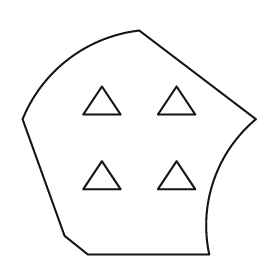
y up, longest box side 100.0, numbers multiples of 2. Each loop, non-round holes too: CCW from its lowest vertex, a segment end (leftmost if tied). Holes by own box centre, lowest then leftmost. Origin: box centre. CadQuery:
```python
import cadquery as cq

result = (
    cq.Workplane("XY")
    .moveTo(-22.0, -48.0)
    .lineTo(30.0, -48.0)
    .threePointArc((32.0, -16.0), (50.0, 10.0))
    .lineTo(0.0, 48.0)
    .threePointArc((-30.0, 36.0), (-50.0, 10.0))
    .lineTo(-32.0, -40.0)
    .close()
    .moveTo(-24.0, -20.0)
    .lineTo(-8.0, -20.0)
    .lineTo(-16.0, -8.0)
    .close()
    .moveTo(8.0, -20.0)
    .lineTo(24.0, -20.0)
    .lineTo(16.0, -8.0)
    .close()
    .moveTo(-24.0, 12.0)
    .lineTo(-8.0, 12.0)
    .lineTo(-16.0, 24.0)
    .close()
    .moveTo(8.0, 12.0)
    .lineTo(24.0, 12.0)
    .lineTo(16.0, 24.0)
    .close()
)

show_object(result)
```